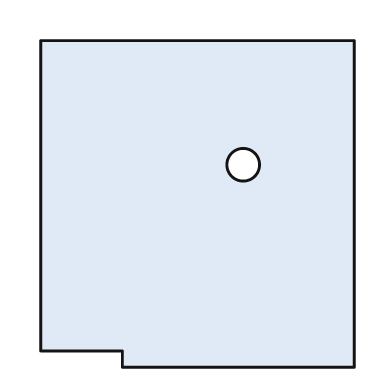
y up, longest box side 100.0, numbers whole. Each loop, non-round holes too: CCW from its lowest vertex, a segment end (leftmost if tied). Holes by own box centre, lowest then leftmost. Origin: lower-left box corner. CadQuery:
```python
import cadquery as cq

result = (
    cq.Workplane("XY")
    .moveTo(25.0, 0.0)
    .lineTo(96.0, 0.0)
    .lineTo(96.0, 100.0)
    .lineTo(0.0, 100.0)
    .lineTo(0.0, 5.0)
    .lineTo(25.0, 5.0)
    .close()
    .moveTo(62.0, 62.0)
    .circle(5.0)
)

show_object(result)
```